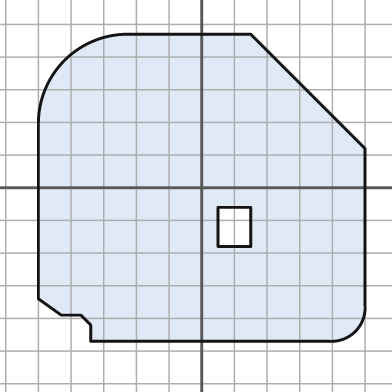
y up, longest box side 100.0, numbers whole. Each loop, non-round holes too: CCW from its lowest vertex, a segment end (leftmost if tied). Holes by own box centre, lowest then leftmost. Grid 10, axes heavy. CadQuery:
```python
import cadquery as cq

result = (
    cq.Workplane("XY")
    .moveTo(-34.0, -47.0)
    .lineTo(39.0, -47.0)
    .threePointArc((47.0, -44.0), (50.0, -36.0))
    .lineTo(50.0, 12.0)
    .lineTo(15.0, 47.0)
    .lineTo(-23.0, 47.0)
    .threePointArc((-42.0, 39.0), (-50.0, 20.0))
    .lineTo(-50.0, -34.0)
    .lineTo(-43.0, -39.0)
    .lineTo(-37.0, -39.0)
    .lineTo(-34.0, -42.0)
    .close()
    .moveTo(5.0, -18.0)
    .lineTo(15.0, -18.0)
    .lineTo(15.0, -6.0)
    .lineTo(5.0, -6.0)
    .close()
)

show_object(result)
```